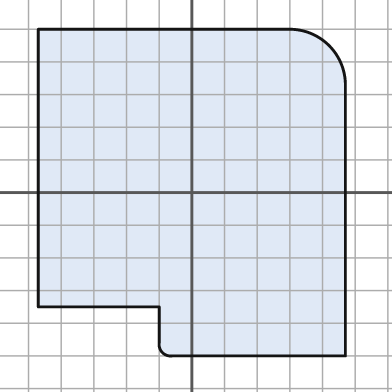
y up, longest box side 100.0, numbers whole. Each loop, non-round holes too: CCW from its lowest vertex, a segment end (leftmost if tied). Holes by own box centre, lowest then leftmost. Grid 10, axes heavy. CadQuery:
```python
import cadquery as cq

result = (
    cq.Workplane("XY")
    .moveTo(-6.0, -50.0)
    .lineTo(47.0, -50.0)
    .lineTo(47.0, 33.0)
    .threePointArc((42.0, 45.0), (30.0, 50.0))
    .lineTo(-47.0, 50.0)
    .lineTo(-47.0, -35.0)
    .lineTo(-10.0, -35.0)
    .lineTo(-10.0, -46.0)
    .threePointArc((-9.0, -49.0), (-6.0, -50.0))
    .close()
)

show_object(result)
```